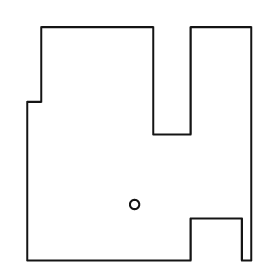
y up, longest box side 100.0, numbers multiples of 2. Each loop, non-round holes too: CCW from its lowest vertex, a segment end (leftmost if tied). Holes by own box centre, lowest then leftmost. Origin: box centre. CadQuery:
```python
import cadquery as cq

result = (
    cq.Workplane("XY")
    .moveTo(-48.0, -50.0)
    .lineTo(22.0, -50.0)
    .lineTo(22.0, -32.0)
    .lineTo(44.0, -32.0)
    .lineTo(44.0, -50.0)
    .lineTo(48.0, -50.0)
    .lineTo(48.0, 50.0)
    .lineTo(22.0, 50.0)
    .lineTo(22.0, 4.0)
    .lineTo(6.0, 4.0)
    .lineTo(6.0, 50.0)
    .lineTo(-42.0, 50.0)
    .lineTo(-42.0, 18.0)
    .lineTo(-48.0, 18.0)
    .close()
    .moveTo(-2.0, -26.0)
    .circle(2.0)
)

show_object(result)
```